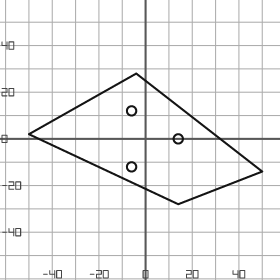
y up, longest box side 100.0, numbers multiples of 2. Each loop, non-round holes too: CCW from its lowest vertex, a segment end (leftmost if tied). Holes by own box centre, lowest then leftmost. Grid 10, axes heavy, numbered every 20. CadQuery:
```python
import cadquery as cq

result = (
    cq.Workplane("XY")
    .moveTo(14.0, -28.0)
    .lineTo(50.0, -14.0)
    .lineTo(-4.0, 28.0)
    .lineTo(-50.0, 2.0)
    .close()
    .moveTo(-6.0, -12.0)
    .circle(2.0)
    .moveTo(14.0, 0.0)
    .circle(2.0)
    .moveTo(-6.0, 12.0)
    .circle(2.0)
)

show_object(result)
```